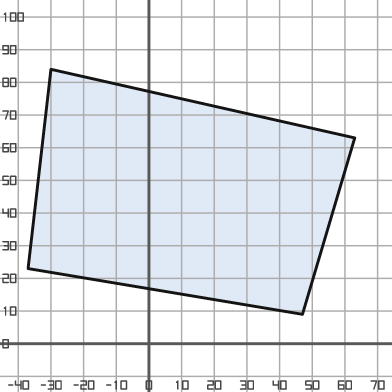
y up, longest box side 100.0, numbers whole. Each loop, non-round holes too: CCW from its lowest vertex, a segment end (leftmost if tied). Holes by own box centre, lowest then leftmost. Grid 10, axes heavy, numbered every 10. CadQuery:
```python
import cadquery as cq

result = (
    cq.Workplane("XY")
    .moveTo(47.0, 9.0)
    .lineTo(63.0, 63.0)
    .lineTo(-30.0, 84.0)
    .lineTo(-37.0, 23.0)
    .close()
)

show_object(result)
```